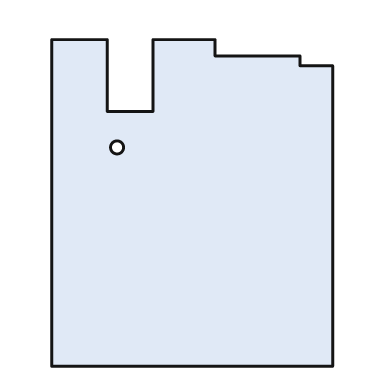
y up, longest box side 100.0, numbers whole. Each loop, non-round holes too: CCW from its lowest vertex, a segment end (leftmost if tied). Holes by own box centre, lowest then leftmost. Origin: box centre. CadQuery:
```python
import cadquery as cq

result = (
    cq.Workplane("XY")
    .moveTo(-43.0, -50.0)
    .lineTo(43.0, -50.0)
    .lineTo(43.0, 42.0)
    .lineTo(33.0, 42.0)
    .lineTo(33.0, 45.0)
    .lineTo(7.0, 45.0)
    .lineTo(7.0, 50.0)
    .lineTo(-12.0, 50.0)
    .lineTo(-12.0, 28.0)
    .lineTo(-26.0, 28.0)
    .lineTo(-26.0, 50.0)
    .lineTo(-43.0, 50.0)
    .close()
    .moveTo(-23.0, 17.0)
    .circle(2.0)
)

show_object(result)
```